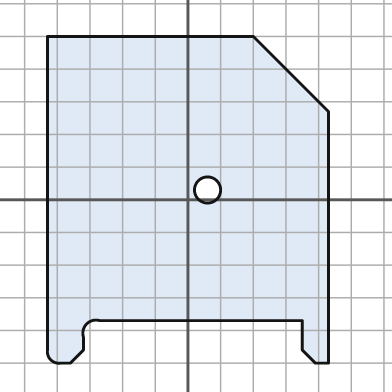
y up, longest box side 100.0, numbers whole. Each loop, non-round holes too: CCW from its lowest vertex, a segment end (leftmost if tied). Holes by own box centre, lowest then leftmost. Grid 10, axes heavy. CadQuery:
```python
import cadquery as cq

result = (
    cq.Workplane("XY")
    .moveTo(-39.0, -50.0)
    .lineTo(-36.0, -50.0)
    .lineTo(-32.0, -46.0)
    .lineTo(-32.0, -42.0)
    .threePointArc((-31.0, -38.0), (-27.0, -37.0))
    .lineTo(35.0, -37.0)
    .lineTo(35.0, -46.0)
    .lineTo(39.0, -50.0)
    .lineTo(43.0, -50.0)
    .lineTo(43.0, 27.0)
    .lineTo(20.0, 50.0)
    .lineTo(-43.0, 50.0)
    .lineTo(-43.0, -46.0)
    .threePointArc((-42.0, -49.0), (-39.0, -50.0))
    .close()
    .moveTo(6.0, 3.0)
    .circle(4.0)
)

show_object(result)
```